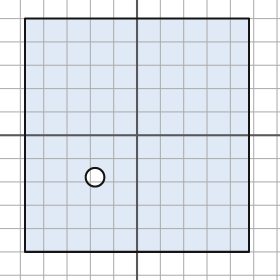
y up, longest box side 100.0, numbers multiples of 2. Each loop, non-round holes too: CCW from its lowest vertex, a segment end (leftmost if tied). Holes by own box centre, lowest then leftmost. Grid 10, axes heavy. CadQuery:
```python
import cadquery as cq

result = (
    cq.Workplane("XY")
    .moveTo(-48.0, -50.0)
    .lineTo(48.0, -50.0)
    .lineTo(48.0, 50.0)
    .lineTo(-48.0, 50.0)
    .close()
    .moveTo(-18.0, -18.0)
    .circle(4.0)
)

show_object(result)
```